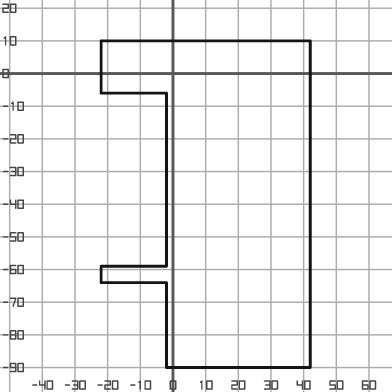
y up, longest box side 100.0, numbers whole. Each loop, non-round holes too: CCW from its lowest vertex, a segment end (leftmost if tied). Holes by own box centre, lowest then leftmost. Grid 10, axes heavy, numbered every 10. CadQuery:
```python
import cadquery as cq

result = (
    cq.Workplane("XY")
    .moveTo(-2.0, -90.0)
    .lineTo(42.0, -90.0)
    .lineTo(42.0, 10.0)
    .lineTo(-22.0, 10.0)
    .lineTo(-22.0, -6.0)
    .lineTo(-2.0, -6.0)
    .lineTo(-2.0, -59.0)
    .lineTo(-22.0, -59.0)
    .lineTo(-22.0, -64.0)
    .lineTo(-2.0, -64.0)
    .close()
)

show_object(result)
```